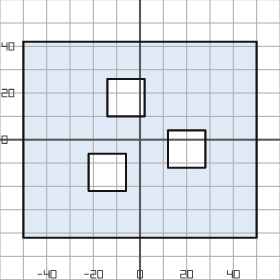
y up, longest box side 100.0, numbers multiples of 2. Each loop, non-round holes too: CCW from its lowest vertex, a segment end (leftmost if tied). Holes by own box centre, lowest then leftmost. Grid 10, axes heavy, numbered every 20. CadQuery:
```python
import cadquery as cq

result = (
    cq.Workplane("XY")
    .moveTo(-50.0, -42.0)
    .lineTo(50.0, -42.0)
    .lineTo(50.0, 42.0)
    .lineTo(-50.0, 42.0)
    .close()
    .moveTo(-22.0, -22.0)
    .lineTo(-6.0, -22.0)
    .lineTo(-6.0, -6.0)
    .lineTo(-22.0, -6.0)
    .close()
    .moveTo(12.0, -12.0)
    .lineTo(28.0, -12.0)
    .lineTo(28.0, 4.0)
    .lineTo(12.0, 4.0)
    .close()
    .moveTo(-14.0, 10.0)
    .lineTo(2.0, 10.0)
    .lineTo(2.0, 26.0)
    .lineTo(-14.0, 26.0)
    .close()
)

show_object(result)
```